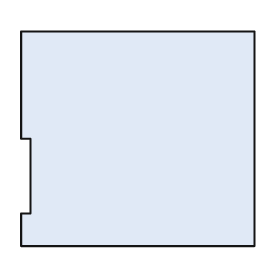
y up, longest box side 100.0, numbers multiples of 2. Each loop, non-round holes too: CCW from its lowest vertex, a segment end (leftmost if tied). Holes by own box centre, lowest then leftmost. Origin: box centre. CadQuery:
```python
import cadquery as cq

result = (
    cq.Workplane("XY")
    .moveTo(-50.0, -46.0)
    .lineTo(50.0, -46.0)
    .lineTo(50.0, 46.0)
    .lineTo(-50.0, 46.0)
    .lineTo(-50.0, 0.0)
    .lineTo(-46.0, 0.0)
    .lineTo(-46.0, -32.0)
    .lineTo(-50.0, -32.0)
    .close()
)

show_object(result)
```